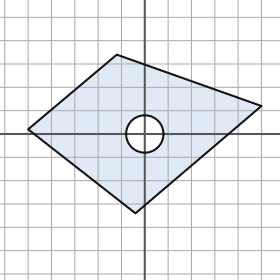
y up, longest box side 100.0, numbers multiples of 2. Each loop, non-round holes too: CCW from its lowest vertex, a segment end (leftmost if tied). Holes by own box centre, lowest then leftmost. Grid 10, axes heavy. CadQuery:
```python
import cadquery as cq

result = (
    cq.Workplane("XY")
    .moveTo(-4.0, -34.0)
    .lineTo(50.0, 12.0)
    .lineTo(-12.0, 34.0)
    .lineTo(-50.0, 2.0)
    .close()
    .moveTo(0.0, 0.0)
    .circle(8.0)
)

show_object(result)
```